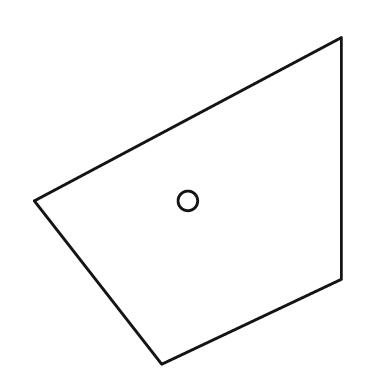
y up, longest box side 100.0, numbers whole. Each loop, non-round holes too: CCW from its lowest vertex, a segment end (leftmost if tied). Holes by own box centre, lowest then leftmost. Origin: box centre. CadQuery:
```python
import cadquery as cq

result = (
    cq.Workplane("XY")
    .moveTo(-8.0, -50.0)
    .lineTo(47.0, -24.0)
    .lineTo(47.0, 50.0)
    .lineTo(-47.0, 0.0)
    .close()
    .moveTo(0.0, 0.0)
    .circle(3.0)
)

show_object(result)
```